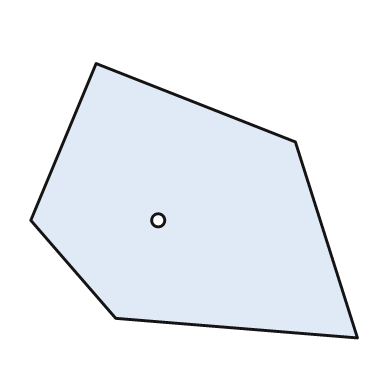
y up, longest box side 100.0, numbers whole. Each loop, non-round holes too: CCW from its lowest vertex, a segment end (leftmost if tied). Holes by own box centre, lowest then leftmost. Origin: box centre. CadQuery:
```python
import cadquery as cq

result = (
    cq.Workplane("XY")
    .moveTo(50.0, -42.0)
    .lineTo(31.0, 18.0)
    .lineTo(-30.0, 42.0)
    .lineTo(-50.0, -6.0)
    .lineTo(-24.0, -36.0)
    .close()
    .moveTo(-11.0, -6.0)
    .circle(2.0)
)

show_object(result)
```